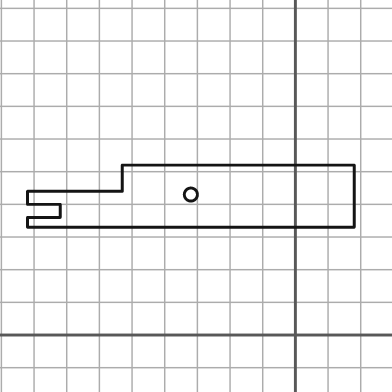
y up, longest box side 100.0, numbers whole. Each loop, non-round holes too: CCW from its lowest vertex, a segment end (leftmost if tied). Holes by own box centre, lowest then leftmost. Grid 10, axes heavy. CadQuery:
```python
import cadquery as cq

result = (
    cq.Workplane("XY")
    .moveTo(-82.0, 33.0)
    .lineTo(18.0, 33.0)
    .lineTo(18.0, 52.0)
    .lineTo(-53.0, 52.0)
    .lineTo(-53.0, 44.0)
    .lineTo(-82.0, 44.0)
    .lineTo(-82.0, 40.0)
    .lineTo(-72.0, 40.0)
    .lineTo(-72.0, 36.0)
    .lineTo(-82.0, 36.0)
    .close()
    .moveTo(-32.0, 43.0)
    .circle(2.0)
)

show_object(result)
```